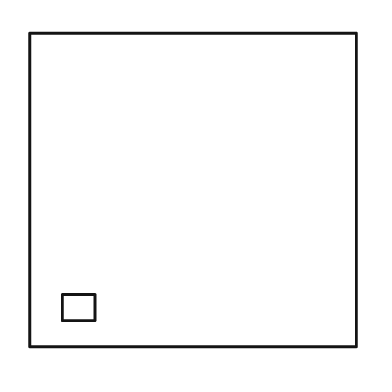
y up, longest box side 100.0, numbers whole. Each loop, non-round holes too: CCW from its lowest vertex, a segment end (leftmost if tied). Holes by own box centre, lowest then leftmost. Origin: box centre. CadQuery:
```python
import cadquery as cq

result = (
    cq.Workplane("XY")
    .moveTo(-50.0, -48.0)
    .lineTo(50.0, -48.0)
    .lineTo(50.0, 48.0)
    .lineTo(-50.0, 48.0)
    .close()
    .moveTo(-40.0, -40.0)
    .lineTo(-30.0, -40.0)
    .lineTo(-30.0, -32.0)
    .lineTo(-40.0, -32.0)
    .close()
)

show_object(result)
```